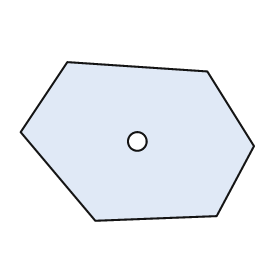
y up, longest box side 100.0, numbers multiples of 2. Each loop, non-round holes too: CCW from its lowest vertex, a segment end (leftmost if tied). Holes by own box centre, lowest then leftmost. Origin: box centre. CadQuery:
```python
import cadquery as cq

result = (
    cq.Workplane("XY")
    .moveTo(-18.0, -34.0)
    .lineTo(34.0, -32.0)
    .lineTo(50.0, -2.0)
    .lineTo(30.0, 30.0)
    .lineTo(-30.0, 34.0)
    .lineTo(-50.0, 4.0)
    .close()
    .moveTo(0.0, 0.0)
    .circle(4.0)
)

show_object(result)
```